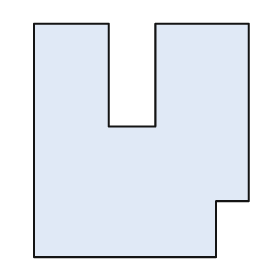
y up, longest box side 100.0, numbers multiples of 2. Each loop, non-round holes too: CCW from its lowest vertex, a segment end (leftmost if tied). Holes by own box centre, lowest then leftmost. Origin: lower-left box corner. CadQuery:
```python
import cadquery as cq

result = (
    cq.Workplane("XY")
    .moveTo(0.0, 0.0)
    .lineTo(78.0, 0.0)
    .lineTo(78.0, 24.0)
    .lineTo(92.0, 24.0)
    .lineTo(92.0, 100.0)
    .lineTo(52.0, 100.0)
    .lineTo(52.0, 56.0)
    .lineTo(32.0, 56.0)
    .lineTo(32.0, 100.0)
    .lineTo(0.0, 100.0)
    .close()
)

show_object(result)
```